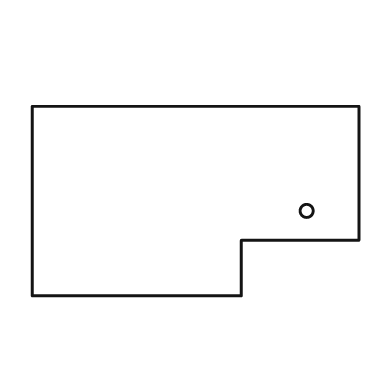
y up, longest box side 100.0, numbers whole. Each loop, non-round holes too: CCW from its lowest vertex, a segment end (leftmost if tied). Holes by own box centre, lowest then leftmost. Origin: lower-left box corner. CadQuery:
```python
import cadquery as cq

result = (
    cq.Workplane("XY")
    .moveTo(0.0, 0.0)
    .lineTo(64.0, 0.0)
    .lineTo(64.0, 17.0)
    .lineTo(100.0, 17.0)
    .lineTo(100.0, 58.0)
    .lineTo(0.0, 58.0)
    .close()
    .moveTo(84.0, 26.0)
    .circle(2.0)
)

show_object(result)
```